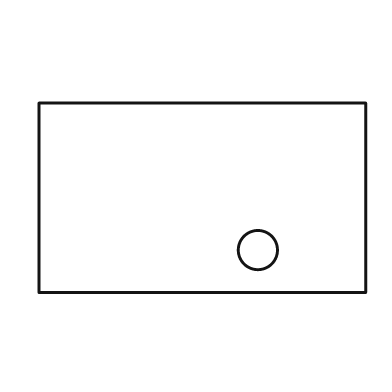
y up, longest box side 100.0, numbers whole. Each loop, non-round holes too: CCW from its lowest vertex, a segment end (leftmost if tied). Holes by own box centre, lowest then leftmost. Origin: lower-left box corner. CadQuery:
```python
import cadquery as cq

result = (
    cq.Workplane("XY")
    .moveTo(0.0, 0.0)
    .lineTo(100.0, 0.0)
    .lineTo(100.0, 58.0)
    .lineTo(0.0, 58.0)
    .close()
    .moveTo(67.0, 13.0)
    .circle(6.0)
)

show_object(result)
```